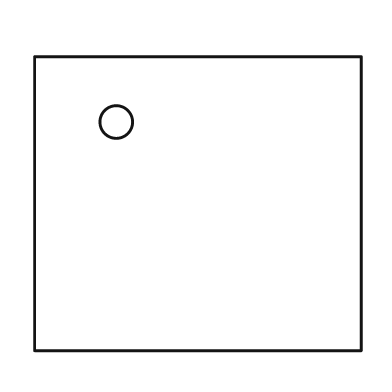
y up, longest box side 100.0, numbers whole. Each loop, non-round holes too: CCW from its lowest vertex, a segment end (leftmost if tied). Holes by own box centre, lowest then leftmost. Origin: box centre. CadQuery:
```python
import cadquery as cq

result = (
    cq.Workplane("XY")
    .moveTo(-50.0, -45.0)
    .lineTo(50.0, -45.0)
    .lineTo(50.0, 45.0)
    .lineTo(-50.0, 45.0)
    .close()
    .moveTo(-25.0, 25.0)
    .circle(5.0)
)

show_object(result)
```